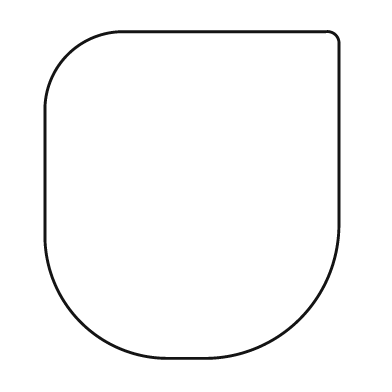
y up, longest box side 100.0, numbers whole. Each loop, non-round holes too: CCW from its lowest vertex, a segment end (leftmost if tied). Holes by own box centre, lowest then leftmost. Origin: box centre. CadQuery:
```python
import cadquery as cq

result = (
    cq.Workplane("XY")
    .moveTo(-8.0, -50.0)
    .lineTo(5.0, -50.0)
    .threePointArc((33.0, -38.0), (45.0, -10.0))
    .lineTo(45.0, 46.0)
    .threePointArc((44.0, 49.0), (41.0, 50.0))
    .lineTo(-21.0, 50.0)
    .threePointArc((-38.0, 43.0), (-45.0, 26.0))
    .lineTo(-45.0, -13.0)
    .threePointArc((-34.0, -39.0), (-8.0, -50.0))
    .close()
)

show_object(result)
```